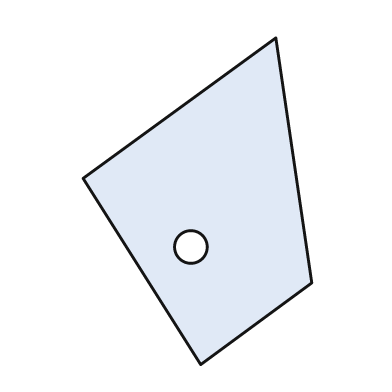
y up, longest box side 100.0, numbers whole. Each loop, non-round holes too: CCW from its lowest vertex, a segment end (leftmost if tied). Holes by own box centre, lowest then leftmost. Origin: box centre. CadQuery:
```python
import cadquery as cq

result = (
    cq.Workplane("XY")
    .moveTo(1.0, -50.0)
    .lineTo(35.0, -25.0)
    .lineTo(24.0, 50.0)
    .lineTo(-35.0, 7.0)
    .close()
    .moveTo(-2.0, -14.0)
    .circle(5.0)
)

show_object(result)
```